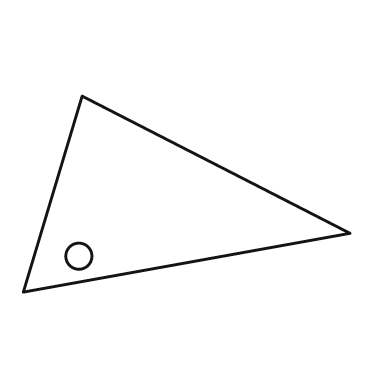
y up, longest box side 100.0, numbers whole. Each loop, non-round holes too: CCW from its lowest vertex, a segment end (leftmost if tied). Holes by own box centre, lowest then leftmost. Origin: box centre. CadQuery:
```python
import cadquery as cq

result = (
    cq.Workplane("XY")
    .moveTo(-50.0, -30.0)
    .lineTo(50.0, -12.0)
    .lineTo(-32.0, 30.0)
    .close()
    .moveTo(-33.0, -19.0)
    .circle(4.0)
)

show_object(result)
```